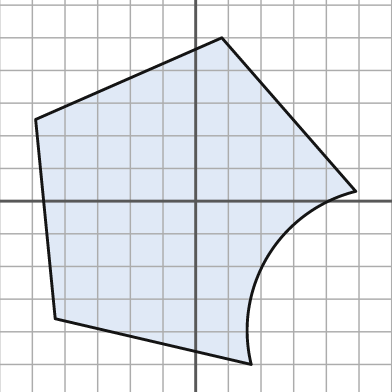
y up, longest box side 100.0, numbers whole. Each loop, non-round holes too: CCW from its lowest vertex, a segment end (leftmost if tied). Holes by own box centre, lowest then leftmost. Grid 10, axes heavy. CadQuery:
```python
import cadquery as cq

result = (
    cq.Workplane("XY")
    .moveTo(17.0, -50.0)
    .threePointArc((22.0, -17.0), (49.0, 3.0))
    .lineTo(8.0, 50.0)
    .lineTo(-49.0, 25.0)
    .lineTo(-43.0, -36.0)
    .close()
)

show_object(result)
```